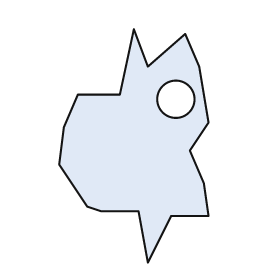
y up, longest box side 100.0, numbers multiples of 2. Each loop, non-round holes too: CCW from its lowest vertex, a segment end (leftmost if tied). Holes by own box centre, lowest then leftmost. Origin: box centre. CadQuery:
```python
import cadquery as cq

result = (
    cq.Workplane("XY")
    .moveTo(6.0, -50.0)
    .lineTo(16.0, -30.0)
    .lineTo(32.0, -30.0)
    .lineTo(30.0, -16.0)
    .lineTo(24.0, -2.0)
    .lineTo(32.0, 10.0)
    .lineTo(28.0, 34.0)
    .lineTo(22.0, 48.0)
    .lineTo(6.0, 34.0)
    .lineTo(0.0, 50.0)
    .lineTo(-6.0, 22.0)
    .lineTo(-24.0, 22.0)
    .lineTo(-30.0, 8.0)
    .lineTo(-32.0, -8.0)
    .lineTo(-20.0, -26.0)
    .lineTo(-14.0, -28.0)
    .lineTo(2.0, -28.0)
    .close()
    .moveTo(18.0, 20.0)
    .circle(8.0)
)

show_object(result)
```